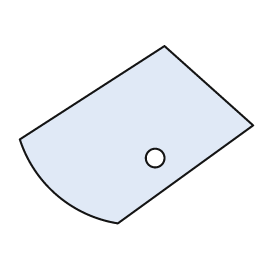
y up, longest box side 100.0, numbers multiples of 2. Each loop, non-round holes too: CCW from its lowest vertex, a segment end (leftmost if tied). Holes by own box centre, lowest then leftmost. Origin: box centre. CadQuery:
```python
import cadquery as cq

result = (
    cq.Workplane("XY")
    .moveTo(-8.0, -38.0)
    .lineTo(50.0, 4.0)
    .lineTo(12.0, 38.0)
    .lineTo(-50.0, -2.0)
    .threePointArc((-34.0, -26.0), (-8.0, -38.0))
    .close()
    .moveTo(8.0, -10.0)
    .circle(4.0)
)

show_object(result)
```